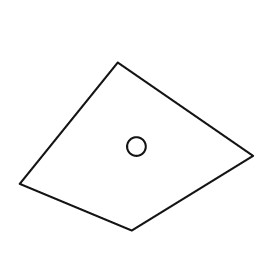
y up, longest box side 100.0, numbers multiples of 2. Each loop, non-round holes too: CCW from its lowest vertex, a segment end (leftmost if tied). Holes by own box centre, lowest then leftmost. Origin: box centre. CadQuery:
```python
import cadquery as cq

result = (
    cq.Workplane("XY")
    .moveTo(-2.0, -36.0)
    .lineTo(50.0, -4.0)
    .lineTo(-8.0, 36.0)
    .lineTo(-50.0, -16.0)
    .close()
    .moveTo(0.0, 0.0)
    .circle(4.0)
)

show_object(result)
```